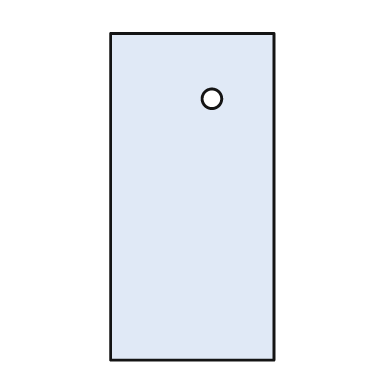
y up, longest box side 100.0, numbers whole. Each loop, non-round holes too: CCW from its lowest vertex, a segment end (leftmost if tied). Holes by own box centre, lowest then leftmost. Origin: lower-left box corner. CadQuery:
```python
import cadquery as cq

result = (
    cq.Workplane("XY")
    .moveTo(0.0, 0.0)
    .lineTo(50.0, 0.0)
    .lineTo(50.0, 100.0)
    .lineTo(0.0, 100.0)
    .close()
    .moveTo(31.0, 80.0)
    .circle(3.0)
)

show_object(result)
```